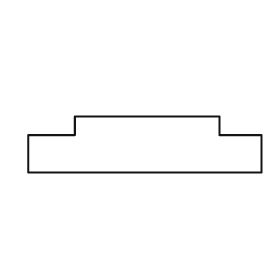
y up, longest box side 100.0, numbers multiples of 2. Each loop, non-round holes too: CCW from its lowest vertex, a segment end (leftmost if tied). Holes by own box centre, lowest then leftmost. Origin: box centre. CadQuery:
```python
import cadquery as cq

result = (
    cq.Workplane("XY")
    .moveTo(-50.0, -12.0)
    .lineTo(50.0, -12.0)
    .lineTo(50.0, 4.0)
    .lineTo(32.0, 4.0)
    .lineTo(32.0, 12.0)
    .lineTo(-30.0, 12.0)
    .lineTo(-30.0, 4.0)
    .lineTo(-50.0, 4.0)
    .close()
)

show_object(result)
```